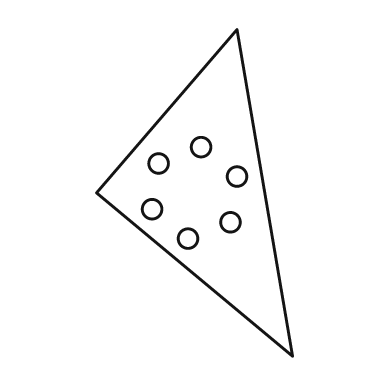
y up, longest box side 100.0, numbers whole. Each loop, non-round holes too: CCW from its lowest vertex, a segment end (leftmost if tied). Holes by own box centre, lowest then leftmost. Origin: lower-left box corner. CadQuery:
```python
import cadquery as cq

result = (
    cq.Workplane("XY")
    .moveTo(60.0, 0.0)
    .lineTo(43.0, 100.0)
    .lineTo(0.0, 50.0)
    .close()
    .moveTo(28.0, 36.0)
    .circle(3.0)
    .moveTo(41.0, 41.0)
    .circle(3.0)
    .moveTo(17.0, 45.0)
    .circle(3.0)
    .moveTo(43.0, 55.0)
    .circle(3.0)
    .moveTo(19.0, 59.0)
    .circle(3.0)
    .moveTo(32.0, 64.0)
    .circle(3.0)
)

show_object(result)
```